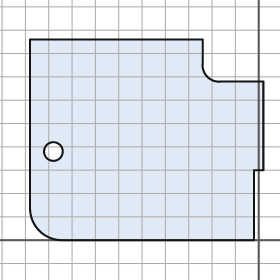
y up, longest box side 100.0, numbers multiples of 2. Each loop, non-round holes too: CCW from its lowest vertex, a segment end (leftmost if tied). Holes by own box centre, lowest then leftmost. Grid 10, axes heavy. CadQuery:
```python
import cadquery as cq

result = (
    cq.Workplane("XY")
    .moveTo(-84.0, 0.0)
    .lineTo(-2.0, 0.0)
    .lineTo(-2.0, 30.0)
    .lineTo(2.0, 30.0)
    .lineTo(2.0, 68.0)
    .lineTo(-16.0, 68.0)
    .threePointArc((-22.0, 70.0), (-24.0, 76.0))
    .lineTo(-24.0, 86.0)
    .lineTo(-98.0, 86.0)
    .lineTo(-98.0, 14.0)
    .threePointArc((-94.0, 4.0), (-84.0, 0.0))
    .close()
    .moveTo(-88.0, 38.0)
    .circle(4.0)
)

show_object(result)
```